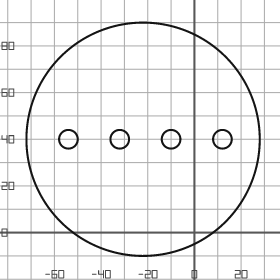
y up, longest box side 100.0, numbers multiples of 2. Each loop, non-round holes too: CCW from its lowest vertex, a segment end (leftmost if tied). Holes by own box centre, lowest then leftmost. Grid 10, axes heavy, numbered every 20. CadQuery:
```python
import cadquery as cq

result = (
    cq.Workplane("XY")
    .moveTo(-22.0, 40.0)
    .circle(50.0)
    .moveTo(-54.0, 40.0)
    .circle(4.0)
    .moveTo(-32.0, 40.0)
    .circle(4.0)
    .moveTo(-10.0, 40.0)
    .circle(4.0)
    .moveTo(12.0, 40.0)
    .circle(4.0)
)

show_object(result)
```